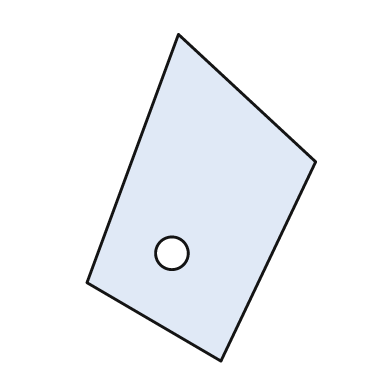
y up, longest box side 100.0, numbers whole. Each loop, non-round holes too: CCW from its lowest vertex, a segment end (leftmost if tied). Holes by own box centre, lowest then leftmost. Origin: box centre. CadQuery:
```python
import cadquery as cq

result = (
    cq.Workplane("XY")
    .moveTo(6.0, -50.0)
    .lineTo(35.0, 11.0)
    .lineTo(-7.0, 50.0)
    .lineTo(-35.0, -26.0)
    .close()
    .moveTo(-9.0, -17.0)
    .circle(5.0)
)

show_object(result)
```